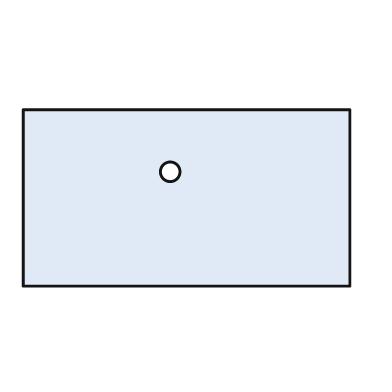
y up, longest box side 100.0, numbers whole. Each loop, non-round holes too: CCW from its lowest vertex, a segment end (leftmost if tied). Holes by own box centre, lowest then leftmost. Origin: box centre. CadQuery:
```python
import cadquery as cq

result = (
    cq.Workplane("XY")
    .moveTo(-50.0, -27.0)
    .lineTo(50.0, -27.0)
    .lineTo(50.0, 27.0)
    .lineTo(-50.0, 27.0)
    .close()
    .moveTo(-5.0, 8.0)
    .circle(3.0)
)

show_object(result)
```